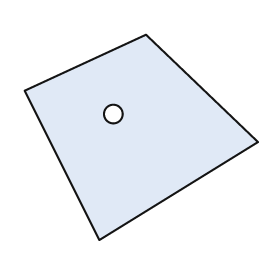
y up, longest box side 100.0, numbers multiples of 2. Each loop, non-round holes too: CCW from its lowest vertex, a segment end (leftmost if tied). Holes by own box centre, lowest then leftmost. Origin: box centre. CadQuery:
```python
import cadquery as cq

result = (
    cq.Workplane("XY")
    .moveTo(-18.0, -44.0)
    .lineTo(50.0, -2.0)
    .lineTo(2.0, 44.0)
    .lineTo(-50.0, 20.0)
    .close()
    .moveTo(-12.0, 10.0)
    .circle(4.0)
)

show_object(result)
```